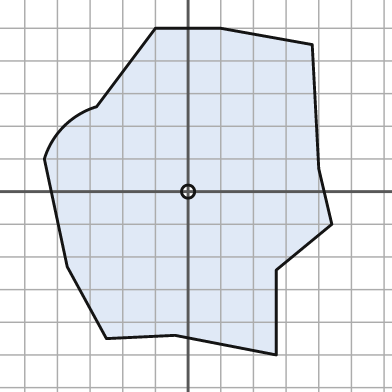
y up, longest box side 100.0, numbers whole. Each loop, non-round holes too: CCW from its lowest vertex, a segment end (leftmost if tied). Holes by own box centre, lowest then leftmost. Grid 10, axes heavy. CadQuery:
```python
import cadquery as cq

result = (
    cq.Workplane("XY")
    .moveTo(27.0, -50.0)
    .lineTo(27.0, -24.0)
    .lineTo(44.0, -10.0)
    .lineTo(40.0, 7.0)
    .lineTo(38.0, 45.0)
    .lineTo(10.0, 50.0)
    .lineTo(-10.0, 50.0)
    .lineTo(-28.0, 26.0)
    .threePointArc((-38.0, 20.0), (-44.0, 10.0))
    .lineTo(-37.0, -23.0)
    .lineTo(-25.0, -45.0)
    .lineTo(-4.0, -44.0)
    .close()
    .moveTo(0.0, 0.0)
    .circle(2.0)
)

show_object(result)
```